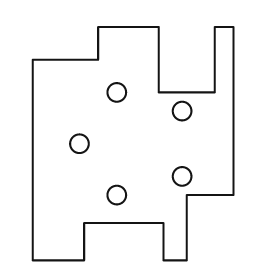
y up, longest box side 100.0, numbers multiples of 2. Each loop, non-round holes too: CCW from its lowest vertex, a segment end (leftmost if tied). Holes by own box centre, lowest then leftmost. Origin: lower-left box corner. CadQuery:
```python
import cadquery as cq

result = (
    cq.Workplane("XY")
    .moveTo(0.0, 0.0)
    .lineTo(22.0, 0.0)
    .lineTo(22.0, 16.0)
    .lineTo(56.0, 16.0)
    .lineTo(56.0, 0.0)
    .lineTo(66.0, 0.0)
    .lineTo(66.0, 28.0)
    .lineTo(86.0, 28.0)
    .lineTo(86.0, 100.0)
    .lineTo(78.0, 100.0)
    .lineTo(78.0, 72.0)
    .lineTo(54.0, 72.0)
    .lineTo(54.0, 100.0)
    .lineTo(28.0, 100.0)
    .lineTo(28.0, 86.0)
    .lineTo(0.0, 86.0)
    .close()
    .moveTo(36.0, 28.0)
    .circle(4.0)
    .moveTo(64.0, 36.0)
    .circle(4.0)
    .moveTo(20.0, 50.0)
    .circle(4.0)
    .moveTo(64.0, 64.0)
    .circle(4.0)
    .moveTo(36.0, 72.0)
    .circle(4.0)
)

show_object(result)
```